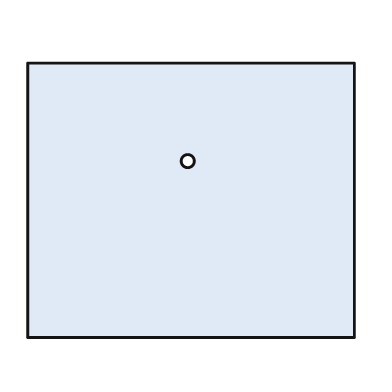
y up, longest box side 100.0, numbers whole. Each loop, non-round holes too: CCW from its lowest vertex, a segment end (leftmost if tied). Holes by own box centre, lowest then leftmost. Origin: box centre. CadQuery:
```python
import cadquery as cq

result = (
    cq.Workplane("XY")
    .moveTo(-50.0, -42.0)
    .lineTo(50.0, -42.0)
    .lineTo(50.0, 42.0)
    .lineTo(-50.0, 42.0)
    .close()
    .moveTo(-1.0, 12.0)
    .circle(2.0)
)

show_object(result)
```